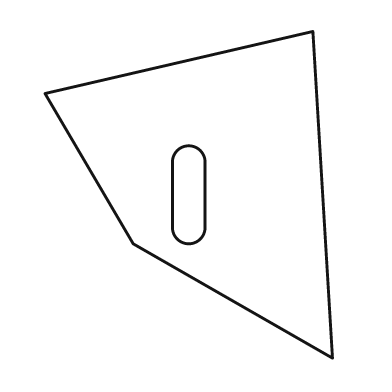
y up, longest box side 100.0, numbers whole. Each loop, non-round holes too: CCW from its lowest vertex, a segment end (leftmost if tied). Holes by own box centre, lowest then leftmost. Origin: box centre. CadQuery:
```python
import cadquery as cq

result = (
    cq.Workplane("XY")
    .moveTo(44.0, -50.0)
    .lineTo(38.0, 50.0)
    .lineTo(-44.0, 31.0)
    .lineTo(-17.0, -15.0)
    .close()
    .moveTo(-5.0, -10.0)
    .threePointArc((0.0, -15.0), (5.0, -10.0))
    .lineTo(5.0, 10.0)
    .threePointArc((0.0, 15.0), (-5.0, 10.0))
    .close()
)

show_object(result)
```